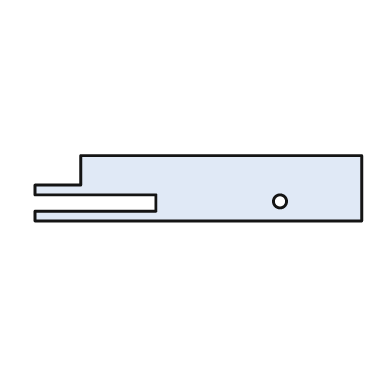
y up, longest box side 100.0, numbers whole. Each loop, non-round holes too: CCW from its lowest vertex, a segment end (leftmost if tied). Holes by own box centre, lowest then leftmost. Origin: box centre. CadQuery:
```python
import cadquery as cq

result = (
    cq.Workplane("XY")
    .moveTo(-50.0, -10.0)
    .lineTo(50.0, -10.0)
    .lineTo(50.0, 10.0)
    .lineTo(-36.0, 10.0)
    .lineTo(-36.0, 1.0)
    .lineTo(-50.0, 1.0)
    .lineTo(-50.0, -2.0)
    .lineTo(-13.0, -2.0)
    .lineTo(-13.0, -7.0)
    .lineTo(-50.0, -7.0)
    .close()
    .moveTo(25.0, -4.0)
    .circle(2.0)
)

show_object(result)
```